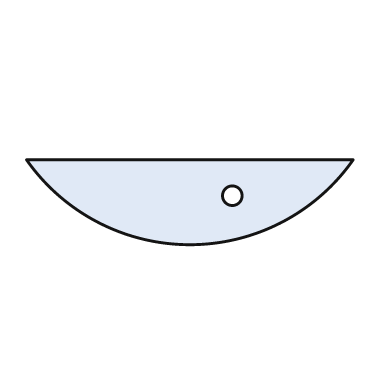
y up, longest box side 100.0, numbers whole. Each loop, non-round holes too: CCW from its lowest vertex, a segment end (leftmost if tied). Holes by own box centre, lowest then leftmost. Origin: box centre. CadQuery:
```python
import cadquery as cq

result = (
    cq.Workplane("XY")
    .moveTo(-50.0, 13.0)
    .threePointArc((0.0, -13.0), (50.0, 13.0))
    .close()
    .moveTo(13.0, 2.0)
    .circle(3.0)
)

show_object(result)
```